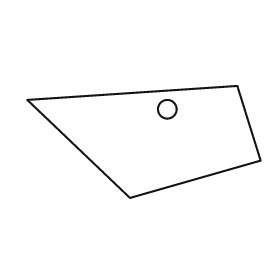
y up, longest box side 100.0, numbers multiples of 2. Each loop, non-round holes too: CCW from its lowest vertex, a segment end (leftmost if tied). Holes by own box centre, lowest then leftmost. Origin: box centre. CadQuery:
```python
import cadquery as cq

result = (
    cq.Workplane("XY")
    .moveTo(-6.0, -24.0)
    .lineTo(50.0, -8.0)
    .lineTo(40.0, 24.0)
    .lineTo(-50.0, 18.0)
    .close()
    .moveTo(10.0, 14.0)
    .circle(4.0)
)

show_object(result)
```